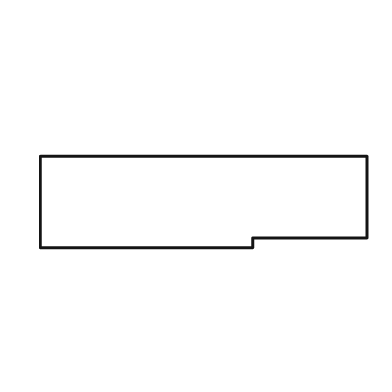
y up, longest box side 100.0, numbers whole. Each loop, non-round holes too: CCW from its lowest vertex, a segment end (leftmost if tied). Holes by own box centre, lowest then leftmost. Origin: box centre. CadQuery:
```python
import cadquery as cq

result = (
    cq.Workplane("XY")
    .moveTo(-50.0, -14.0)
    .lineTo(15.0, -14.0)
    .lineTo(15.0, -11.0)
    .lineTo(50.0, -11.0)
    .lineTo(50.0, 14.0)
    .lineTo(-50.0, 14.0)
    .close()
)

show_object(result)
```